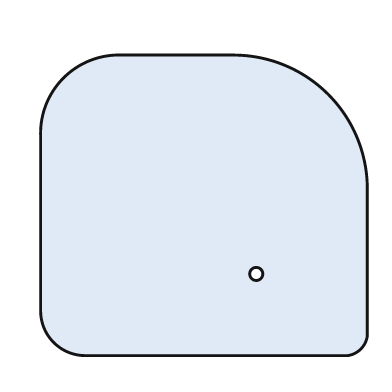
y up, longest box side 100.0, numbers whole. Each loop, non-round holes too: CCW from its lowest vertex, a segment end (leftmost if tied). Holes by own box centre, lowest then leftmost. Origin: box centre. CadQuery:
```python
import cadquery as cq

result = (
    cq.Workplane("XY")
    .moveTo(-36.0, -46.0)
    .lineTo(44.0, -46.0)
    .threePointArc((48.0, -44.0), (50.0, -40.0))
    .lineTo(50.0, 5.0)
    .threePointArc((38.0, 34.0), (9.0, 46.0))
    .lineTo(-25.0, 46.0)
    .threePointArc((-43.0, 39.0), (-50.0, 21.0))
    .lineTo(-50.0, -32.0)
    .threePointArc((-46.0, -42.0), (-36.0, -46.0))
    .close()
    .moveTo(16.0, -21.0)
    .circle(2.0)
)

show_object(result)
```